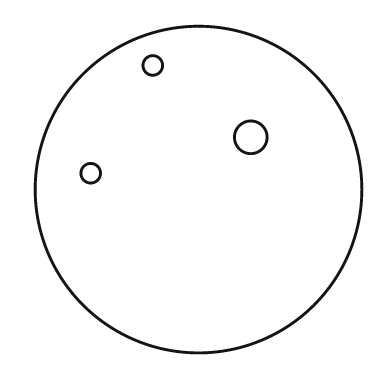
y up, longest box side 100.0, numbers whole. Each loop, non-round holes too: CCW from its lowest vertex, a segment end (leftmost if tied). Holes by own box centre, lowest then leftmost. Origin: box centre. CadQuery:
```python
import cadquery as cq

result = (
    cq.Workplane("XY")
    .moveTo(0.0, 0.0)
    .circle(50.0)
    .moveTo(-33.0, 5.0)
    .circle(3.0)
    .moveTo(16.0, 16.0)
    .circle(5.0)
    .moveTo(-14.0, 38.0)
    .circle(3.0)
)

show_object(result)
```